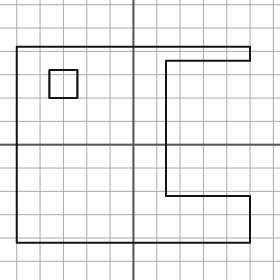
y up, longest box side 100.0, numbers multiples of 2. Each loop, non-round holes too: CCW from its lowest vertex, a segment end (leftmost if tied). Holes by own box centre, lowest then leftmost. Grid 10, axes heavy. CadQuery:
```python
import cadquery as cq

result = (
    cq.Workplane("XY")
    .moveTo(-50.0, -42.0)
    .lineTo(50.0, -42.0)
    .lineTo(50.0, -22.0)
    .lineTo(14.0, -22.0)
    .lineTo(14.0, 36.0)
    .lineTo(50.0, 36.0)
    .lineTo(50.0, 42.0)
    .lineTo(-50.0, 42.0)
    .close()
    .moveTo(-36.0, 20.0)
    .lineTo(-24.0, 20.0)
    .lineTo(-24.0, 32.0)
    .lineTo(-36.0, 32.0)
    .close()
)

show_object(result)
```